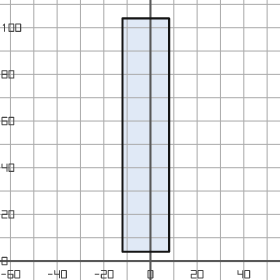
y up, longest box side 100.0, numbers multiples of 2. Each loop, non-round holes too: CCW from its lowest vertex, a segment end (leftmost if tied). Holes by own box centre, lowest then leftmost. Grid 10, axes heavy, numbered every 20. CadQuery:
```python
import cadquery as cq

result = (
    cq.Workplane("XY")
    .moveTo(-12.0, 4.0)
    .lineTo(8.0, 4.0)
    .lineTo(8.0, 104.0)
    .lineTo(-12.0, 104.0)
    .close()
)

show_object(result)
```